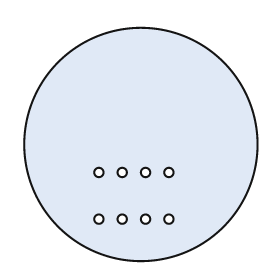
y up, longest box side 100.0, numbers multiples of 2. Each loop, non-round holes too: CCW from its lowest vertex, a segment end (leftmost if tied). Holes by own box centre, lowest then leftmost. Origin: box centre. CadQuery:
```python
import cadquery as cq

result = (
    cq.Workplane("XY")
    .moveTo(0.0, 0.0)
    .circle(50.0)
    .moveTo(-18.0, -32.0)
    .circle(2.0)
    .moveTo(-8.0, -32.0)
    .circle(2.0)
    .moveTo(2.0, -32.0)
    .circle(2.0)
    .moveTo(12.0, -32.0)
    .circle(2.0)
    .moveTo(-18.0, -12.0)
    .circle(2.0)
    .moveTo(-8.0, -12.0)
    .circle(2.0)
    .moveTo(2.0, -12.0)
    .circle(2.0)
    .moveTo(12.0, -12.0)
    .circle(2.0)
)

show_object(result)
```